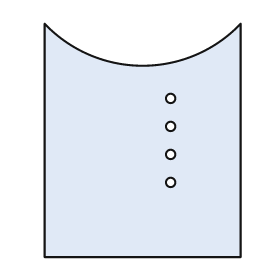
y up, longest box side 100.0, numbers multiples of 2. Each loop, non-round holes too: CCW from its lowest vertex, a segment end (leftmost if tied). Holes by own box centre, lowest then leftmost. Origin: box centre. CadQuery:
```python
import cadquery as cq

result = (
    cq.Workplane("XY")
    .moveTo(-42.0, -50.0)
    .lineTo(42.0, -50.0)
    .lineTo(42.0, 50.0)
    .threePointArc((0.0, 32.0), (-42.0, 50.0))
    .close()
    .moveTo(12.0, -18.0)
    .circle(2.0)
    .moveTo(12.0, -6.0)
    .circle(2.0)
    .moveTo(12.0, 6.0)
    .circle(2.0)
    .moveTo(12.0, 18.0)
    .circle(2.0)
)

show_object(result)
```